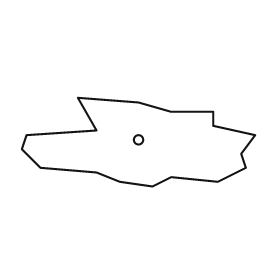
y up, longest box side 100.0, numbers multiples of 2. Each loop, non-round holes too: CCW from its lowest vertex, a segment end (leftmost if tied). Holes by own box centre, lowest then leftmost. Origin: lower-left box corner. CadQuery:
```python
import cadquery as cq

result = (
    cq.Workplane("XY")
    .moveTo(56.0, 0.0)
    .lineTo(64.0, 4.0)
    .lineTo(84.0, 2.0)
    .lineTo(96.0, 8.0)
    .lineTo(94.0, 14.0)
    .lineTo(100.0, 22.0)
    .lineTo(82.0, 26.0)
    .lineTo(82.0, 32.0)
    .lineTo(64.0, 32.0)
    .lineTo(50.0, 36.0)
    .lineTo(24.0, 38.0)
    .lineTo(32.0, 24.0)
    .lineTo(2.0, 22.0)
    .lineTo(0.0, 16.0)
    .lineTo(8.0, 8.0)
    .lineTo(32.0, 6.0)
    .lineTo(42.0, 2.0)
    .close()
    .moveTo(50.0, 20.0)
    .circle(2.0)
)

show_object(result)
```